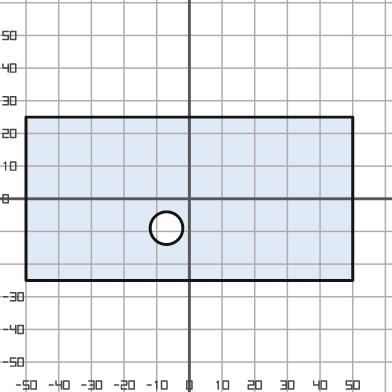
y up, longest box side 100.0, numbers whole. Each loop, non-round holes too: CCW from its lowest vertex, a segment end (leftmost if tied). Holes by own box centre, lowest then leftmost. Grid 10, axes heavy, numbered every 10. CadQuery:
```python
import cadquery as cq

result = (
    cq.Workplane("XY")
    .moveTo(-50.0, -25.0)
    .lineTo(50.0, -25.0)
    .lineTo(50.0, 25.0)
    .lineTo(-50.0, 25.0)
    .close()
    .moveTo(-7.0, -9.0)
    .circle(5.0)
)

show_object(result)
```